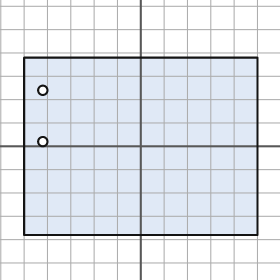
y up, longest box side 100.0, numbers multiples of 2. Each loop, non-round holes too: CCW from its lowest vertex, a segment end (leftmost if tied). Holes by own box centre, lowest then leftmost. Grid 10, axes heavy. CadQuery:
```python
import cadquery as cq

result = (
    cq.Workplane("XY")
    .moveTo(-50.0, -38.0)
    .lineTo(50.0, -38.0)
    .lineTo(50.0, 38.0)
    .lineTo(-50.0, 38.0)
    .close()
    .moveTo(-42.0, 2.0)
    .circle(2.0)
    .moveTo(-42.0, 24.0)
    .circle(2.0)
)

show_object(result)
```